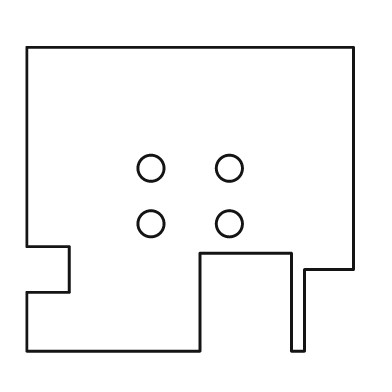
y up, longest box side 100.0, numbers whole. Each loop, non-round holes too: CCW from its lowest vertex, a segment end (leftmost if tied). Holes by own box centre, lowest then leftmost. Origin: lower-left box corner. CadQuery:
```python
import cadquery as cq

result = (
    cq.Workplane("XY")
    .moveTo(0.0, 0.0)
    .lineTo(53.0, 0.0)
    .lineTo(53.0, 30.0)
    .lineTo(81.0, 30.0)
    .lineTo(81.0, 0.0)
    .lineTo(85.0, 0.0)
    .lineTo(85.0, 25.0)
    .lineTo(100.0, 25.0)
    .lineTo(100.0, 93.0)
    .lineTo(0.0, 93.0)
    .lineTo(0.0, 32.0)
    .lineTo(13.0, 32.0)
    .lineTo(13.0, 18.0)
    .lineTo(0.0, 18.0)
    .close()
    .moveTo(38.0, 39.0)
    .circle(4.0)
    .moveTo(62.0, 39.0)
    .circle(4.0)
    .moveTo(38.0, 56.0)
    .circle(4.0)
    .moveTo(62.0, 56.0)
    .circle(4.0)
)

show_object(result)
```